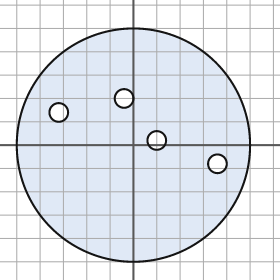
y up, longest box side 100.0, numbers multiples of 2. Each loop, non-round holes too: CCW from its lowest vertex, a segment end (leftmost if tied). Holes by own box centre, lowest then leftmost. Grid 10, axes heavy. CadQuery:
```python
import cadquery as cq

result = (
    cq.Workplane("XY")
    .moveTo(0.0, 0.0)
    .circle(50.0)
    .moveTo(36.0, -8.0)
    .circle(4.0)
    .moveTo(10.0, 2.0)
    .circle(4.0)
    .moveTo(-32.0, 14.0)
    .circle(4.0)
    .moveTo(-4.0, 20.0)
    .circle(4.0)
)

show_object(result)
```